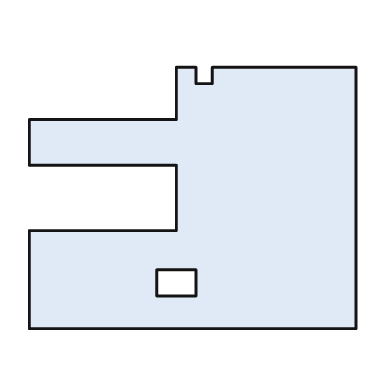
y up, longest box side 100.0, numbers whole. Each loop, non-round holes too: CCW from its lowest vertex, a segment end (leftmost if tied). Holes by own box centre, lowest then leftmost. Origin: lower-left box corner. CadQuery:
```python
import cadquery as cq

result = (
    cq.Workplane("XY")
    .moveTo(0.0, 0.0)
    .lineTo(100.0, 0.0)
    .lineTo(100.0, 80.0)
    .lineTo(56.0, 80.0)
    .lineTo(56.0, 75.0)
    .lineTo(51.0, 75.0)
    .lineTo(51.0, 80.0)
    .lineTo(45.0, 80.0)
    .lineTo(45.0, 64.0)
    .lineTo(0.0, 64.0)
    .lineTo(0.0, 50.0)
    .lineTo(45.0, 50.0)
    .lineTo(45.0, 30.0)
    .lineTo(0.0, 30.0)
    .close()
    .moveTo(39.0, 10.0)
    .lineTo(51.0, 10.0)
    .lineTo(51.0, 18.0)
    .lineTo(39.0, 18.0)
    .close()
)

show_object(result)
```